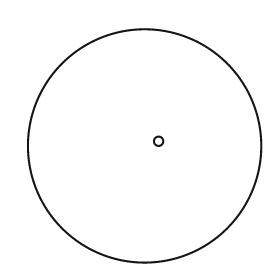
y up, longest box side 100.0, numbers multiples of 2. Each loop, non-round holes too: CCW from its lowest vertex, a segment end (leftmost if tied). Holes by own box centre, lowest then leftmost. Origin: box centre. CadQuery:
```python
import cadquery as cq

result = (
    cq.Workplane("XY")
    .moveTo(0.0, 0.0)
    .circle(50.0)
    .moveTo(6.0, 2.0)
    .circle(2.0)
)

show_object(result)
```